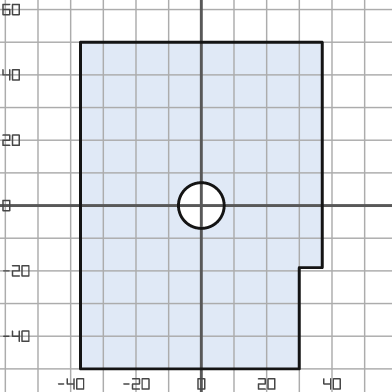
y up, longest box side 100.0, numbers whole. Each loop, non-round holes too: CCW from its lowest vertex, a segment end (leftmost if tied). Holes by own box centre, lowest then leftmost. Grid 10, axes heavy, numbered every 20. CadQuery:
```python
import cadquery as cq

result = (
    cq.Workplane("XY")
    .moveTo(-37.0, -50.0)
    .lineTo(30.0, -50.0)
    .lineTo(30.0, -19.0)
    .lineTo(37.0, -19.0)
    .lineTo(37.0, 50.0)
    .lineTo(-37.0, 50.0)
    .close()
    .moveTo(0.0, 0.0)
    .circle(7.0)
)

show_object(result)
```